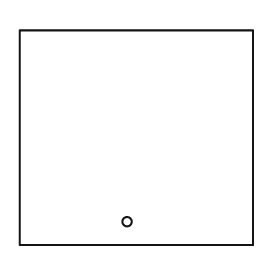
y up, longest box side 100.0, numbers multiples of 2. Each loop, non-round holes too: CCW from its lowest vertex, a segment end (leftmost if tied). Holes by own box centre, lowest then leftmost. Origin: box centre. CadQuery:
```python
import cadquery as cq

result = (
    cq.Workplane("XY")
    .moveTo(-50.0, -46.0)
    .lineTo(50.0, -46.0)
    .lineTo(50.0, 46.0)
    .lineTo(-50.0, 46.0)
    .close()
    .moveTo(-4.0, -36.0)
    .circle(2.0)
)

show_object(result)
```